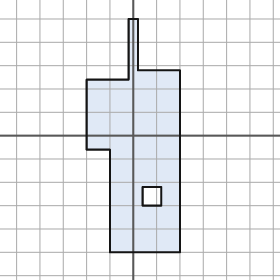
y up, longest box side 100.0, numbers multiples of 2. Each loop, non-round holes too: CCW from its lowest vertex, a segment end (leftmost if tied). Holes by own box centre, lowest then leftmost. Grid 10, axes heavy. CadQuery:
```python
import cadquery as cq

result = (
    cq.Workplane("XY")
    .moveTo(-10.0, -50.0)
    .lineTo(20.0, -50.0)
    .lineTo(20.0, 28.0)
    .lineTo(2.0, 28.0)
    .lineTo(2.0, 50.0)
    .lineTo(-2.0, 50.0)
    .lineTo(-2.0, 24.0)
    .lineTo(-20.0, 24.0)
    .lineTo(-20.0, -6.0)
    .lineTo(-10.0, -6.0)
    .close()
    .moveTo(4.0, -30.0)
    .lineTo(12.0, -30.0)
    .lineTo(12.0, -22.0)
    .lineTo(4.0, -22.0)
    .close()
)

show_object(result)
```